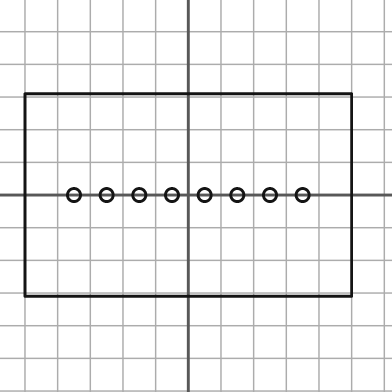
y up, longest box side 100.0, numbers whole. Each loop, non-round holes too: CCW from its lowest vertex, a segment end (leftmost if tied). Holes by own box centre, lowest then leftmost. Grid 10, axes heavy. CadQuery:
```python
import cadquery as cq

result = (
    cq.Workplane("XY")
    .moveTo(-50.0, -31.0)
    .lineTo(50.0, -31.0)
    .lineTo(50.0, 31.0)
    .lineTo(-50.0, 31.0)
    .close()
    .moveTo(-35.0, 0.0)
    .circle(2.0)
    .moveTo(-25.0, 0.0)
    .circle(2.0)
    .moveTo(-15.0, 0.0)
    .circle(2.0)
    .moveTo(-5.0, 0.0)
    .circle(2.0)
    .moveTo(5.0, 0.0)
    .circle(2.0)
    .moveTo(15.0, 0.0)
    .circle(2.0)
    .moveTo(25.0, 0.0)
    .circle(2.0)
    .moveTo(35.0, 0.0)
    .circle(2.0)
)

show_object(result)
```